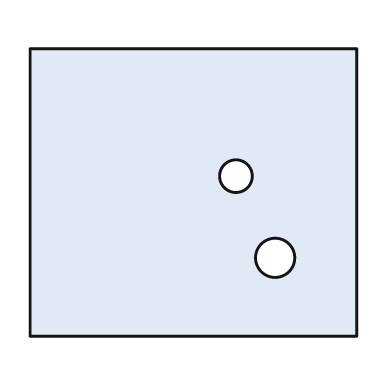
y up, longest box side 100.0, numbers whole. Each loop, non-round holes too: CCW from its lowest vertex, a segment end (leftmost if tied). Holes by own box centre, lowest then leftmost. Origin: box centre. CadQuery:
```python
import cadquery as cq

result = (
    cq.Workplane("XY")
    .moveTo(-50.0, -44.0)
    .lineTo(50.0, -44.0)
    .lineTo(50.0, 44.0)
    .lineTo(-50.0, 44.0)
    .close()
    .moveTo(25.0, -20.0)
    .circle(6.0)
    .moveTo(13.0, 5.0)
    .circle(5.0)
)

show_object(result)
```